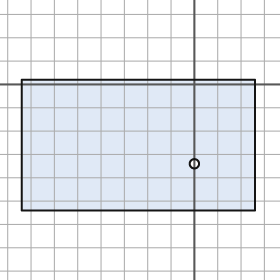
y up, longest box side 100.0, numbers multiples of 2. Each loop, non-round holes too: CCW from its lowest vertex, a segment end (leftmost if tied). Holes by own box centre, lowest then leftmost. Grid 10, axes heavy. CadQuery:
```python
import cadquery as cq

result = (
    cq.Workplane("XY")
    .moveTo(-74.0, -54.0)
    .lineTo(26.0, -54.0)
    .lineTo(26.0, 2.0)
    .lineTo(-74.0, 2.0)
    .close()
    .moveTo(0.0, -34.0)
    .circle(2.0)
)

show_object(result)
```